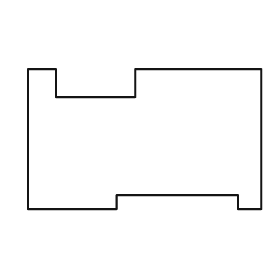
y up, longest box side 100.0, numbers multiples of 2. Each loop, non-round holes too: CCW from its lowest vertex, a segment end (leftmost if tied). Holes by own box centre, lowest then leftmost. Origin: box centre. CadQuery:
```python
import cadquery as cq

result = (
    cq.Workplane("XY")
    .moveTo(-50.0, -30.0)
    .lineTo(-12.0, -30.0)
    .lineTo(-12.0, -24.0)
    .lineTo(40.0, -24.0)
    .lineTo(40.0, -30.0)
    .lineTo(50.0, -30.0)
    .lineTo(50.0, 30.0)
    .lineTo(-4.0, 30.0)
    .lineTo(-4.0, 18.0)
    .lineTo(-38.0, 18.0)
    .lineTo(-38.0, 30.0)
    .lineTo(-50.0, 30.0)
    .close()
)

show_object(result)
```